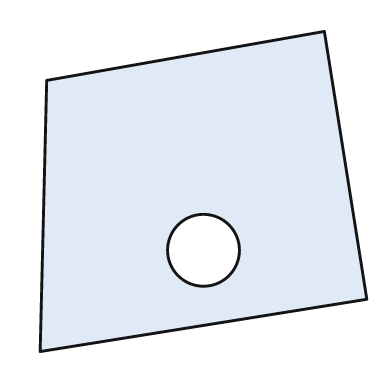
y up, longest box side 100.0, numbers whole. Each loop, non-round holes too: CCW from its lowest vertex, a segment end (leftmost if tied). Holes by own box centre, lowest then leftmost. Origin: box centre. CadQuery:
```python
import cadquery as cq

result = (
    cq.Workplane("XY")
    .moveTo(-50.0, -49.0)
    .lineTo(50.0, -33.0)
    .lineTo(37.0, 49.0)
    .lineTo(-48.0, 34.0)
    .close()
    .moveTo(0.0, -18.0)
    .circle(11.0)
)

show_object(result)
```